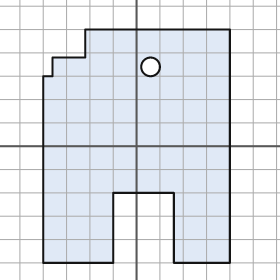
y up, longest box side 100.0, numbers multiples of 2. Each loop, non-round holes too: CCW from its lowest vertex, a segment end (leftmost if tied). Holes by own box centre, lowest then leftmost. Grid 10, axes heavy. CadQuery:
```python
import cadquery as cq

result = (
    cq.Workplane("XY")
    .moveTo(-40.0, -50.0)
    .lineTo(-10.0, -50.0)
    .lineTo(-10.0, -20.0)
    .lineTo(16.0, -20.0)
    .lineTo(16.0, -50.0)
    .lineTo(40.0, -50.0)
    .lineTo(40.0, 50.0)
    .lineTo(-22.0, 50.0)
    .lineTo(-22.0, 38.0)
    .lineTo(-36.0, 38.0)
    .lineTo(-36.0, 30.0)
    .lineTo(-40.0, 30.0)
    .close()
    .moveTo(6.0, 34.0)
    .circle(4.0)
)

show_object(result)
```